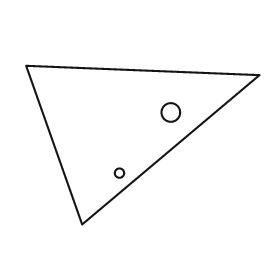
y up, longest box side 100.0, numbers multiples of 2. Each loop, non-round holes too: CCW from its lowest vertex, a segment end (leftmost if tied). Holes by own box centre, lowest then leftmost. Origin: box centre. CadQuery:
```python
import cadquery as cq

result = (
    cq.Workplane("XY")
    .moveTo(-26.0, -34.0)
    .lineTo(50.0, 30.0)
    .lineTo(-50.0, 34.0)
    .close()
    .moveTo(-10.0, -12.0)
    .circle(2.0)
    .moveTo(12.0, 14.0)
    .circle(4.0)
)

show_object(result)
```